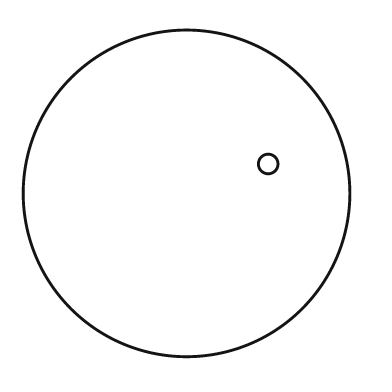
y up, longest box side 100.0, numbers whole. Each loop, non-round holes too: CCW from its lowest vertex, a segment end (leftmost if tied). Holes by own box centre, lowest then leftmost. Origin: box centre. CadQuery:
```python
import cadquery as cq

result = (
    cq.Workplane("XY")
    .moveTo(0.0, 0.0)
    .circle(50.0)
    .moveTo(25.0, 9.0)
    .circle(3.0)
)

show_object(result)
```